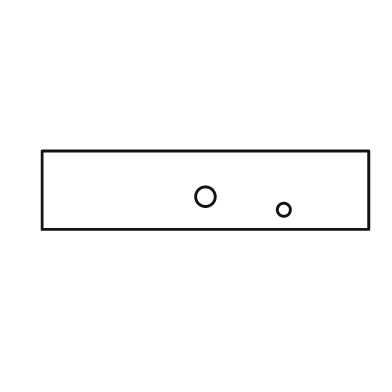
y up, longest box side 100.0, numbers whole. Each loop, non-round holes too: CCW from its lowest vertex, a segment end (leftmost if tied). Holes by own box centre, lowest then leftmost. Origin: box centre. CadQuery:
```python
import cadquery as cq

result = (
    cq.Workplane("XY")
    .moveTo(-50.0, -12.0)
    .lineTo(50.0, -12.0)
    .lineTo(50.0, 12.0)
    .lineTo(-50.0, 12.0)
    .close()
    .moveTo(24.0, -6.0)
    .circle(2.0)
    .moveTo(0.0, -2.0)
    .circle(3.0)
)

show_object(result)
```